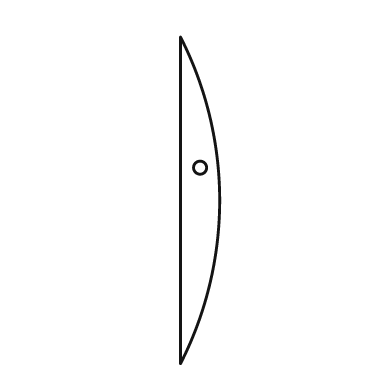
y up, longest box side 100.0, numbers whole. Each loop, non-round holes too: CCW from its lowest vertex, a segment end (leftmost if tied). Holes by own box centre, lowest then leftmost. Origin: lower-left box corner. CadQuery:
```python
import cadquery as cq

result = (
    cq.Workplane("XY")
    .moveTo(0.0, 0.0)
    .threePointArc((12.0, 50.0), (0.0, 100.0))
    .close()
    .moveTo(6.0, 60.0)
    .circle(2.0)
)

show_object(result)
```